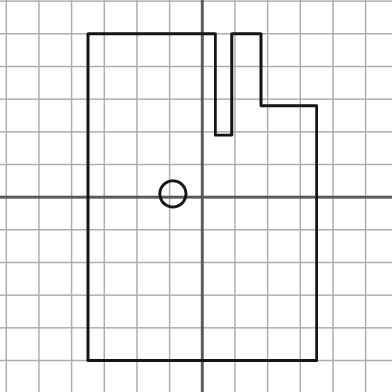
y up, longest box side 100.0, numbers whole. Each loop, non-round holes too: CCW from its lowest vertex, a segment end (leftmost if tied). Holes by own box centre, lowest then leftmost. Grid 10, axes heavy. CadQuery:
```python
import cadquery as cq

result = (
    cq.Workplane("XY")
    .moveTo(-35.0, -50.0)
    .lineTo(35.0, -50.0)
    .lineTo(35.0, 28.0)
    .lineTo(18.0, 28.0)
    .lineTo(18.0, 50.0)
    .lineTo(9.0, 50.0)
    .lineTo(9.0, 19.0)
    .lineTo(4.0, 19.0)
    .lineTo(4.0, 50.0)
    .lineTo(-35.0, 50.0)
    .close()
    .moveTo(-9.0, 1.0)
    .circle(4.0)
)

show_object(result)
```